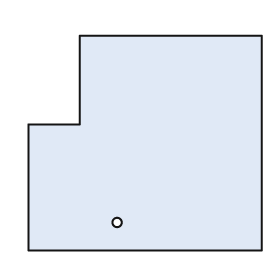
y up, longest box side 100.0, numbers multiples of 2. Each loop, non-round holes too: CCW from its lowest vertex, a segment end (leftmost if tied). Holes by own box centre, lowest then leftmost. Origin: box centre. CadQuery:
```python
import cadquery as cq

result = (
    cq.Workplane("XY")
    .moveTo(-50.0, -46.0)
    .lineTo(50.0, -46.0)
    .lineTo(50.0, 46.0)
    .lineTo(-28.0, 46.0)
    .lineTo(-28.0, 8.0)
    .lineTo(-50.0, 8.0)
    .close()
    .moveTo(-12.0, -34.0)
    .circle(2.0)
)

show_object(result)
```